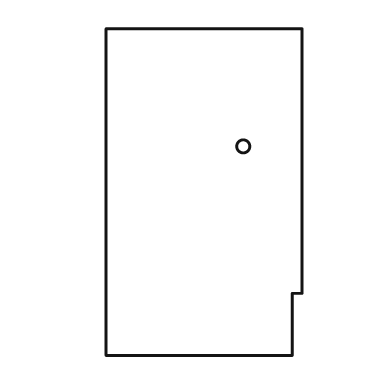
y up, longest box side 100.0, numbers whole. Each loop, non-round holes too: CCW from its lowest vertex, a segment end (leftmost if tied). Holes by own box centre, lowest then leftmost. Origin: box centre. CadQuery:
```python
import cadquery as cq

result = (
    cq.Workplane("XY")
    .moveTo(-30.0, -50.0)
    .lineTo(27.0, -50.0)
    .lineTo(27.0, -31.0)
    .lineTo(30.0, -31.0)
    .lineTo(30.0, 50.0)
    .lineTo(-30.0, 50.0)
    .close()
    .moveTo(12.0, 14.0)
    .circle(2.0)
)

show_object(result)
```